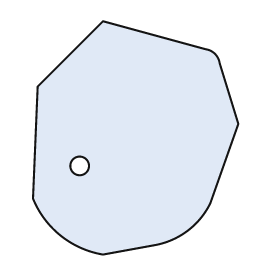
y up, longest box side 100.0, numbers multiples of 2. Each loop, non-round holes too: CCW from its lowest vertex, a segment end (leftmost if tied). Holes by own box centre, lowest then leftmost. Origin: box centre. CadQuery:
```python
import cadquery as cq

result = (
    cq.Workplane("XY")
    .moveTo(-14.0, -50.0)
    .lineTo(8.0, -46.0)
    .threePointArc((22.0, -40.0), (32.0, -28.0))
    .lineTo(44.0, 6.0)
    .lineTo(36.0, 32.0)
    .threePointArc((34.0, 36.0), (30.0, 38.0))
    .lineTo(-14.0, 50.0)
    .lineTo(-42.0, 22.0)
    .lineTo(-44.0, -26.0)
    .threePointArc((-32.0, -42.0), (-14.0, -50.0))
    .close()
    .moveTo(-24.0, -12.0)
    .circle(4.0)
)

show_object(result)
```